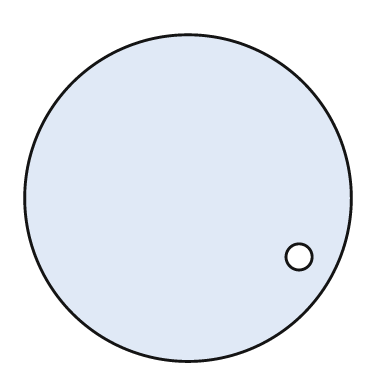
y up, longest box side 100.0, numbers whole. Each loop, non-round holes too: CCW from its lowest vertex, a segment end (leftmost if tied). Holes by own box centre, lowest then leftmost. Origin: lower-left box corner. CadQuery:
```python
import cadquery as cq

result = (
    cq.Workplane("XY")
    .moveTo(50.0, 50.0)
    .circle(50.0)
    .moveTo(84.0, 32.0)
    .circle(4.0)
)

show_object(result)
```